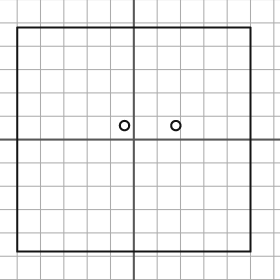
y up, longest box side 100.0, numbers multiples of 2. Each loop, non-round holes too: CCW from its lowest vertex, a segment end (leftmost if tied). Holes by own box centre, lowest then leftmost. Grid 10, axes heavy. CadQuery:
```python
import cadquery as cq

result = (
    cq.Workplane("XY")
    .moveTo(-50.0, -48.0)
    .lineTo(50.0, -48.0)
    .lineTo(50.0, 48.0)
    .lineTo(-50.0, 48.0)
    .close()
    .moveTo(-4.0, 6.0)
    .circle(2.0)
    .moveTo(18.0, 6.0)
    .circle(2.0)
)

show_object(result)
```